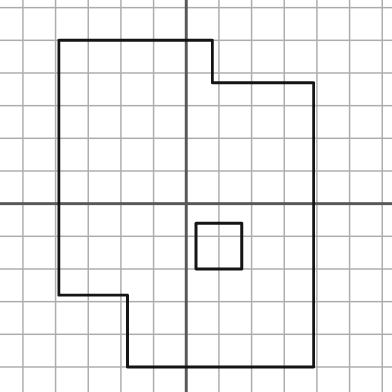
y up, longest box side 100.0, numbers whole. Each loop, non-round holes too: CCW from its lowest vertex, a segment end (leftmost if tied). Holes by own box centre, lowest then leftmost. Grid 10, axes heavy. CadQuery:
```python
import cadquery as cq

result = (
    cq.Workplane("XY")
    .moveTo(-18.0, -50.0)
    .lineTo(39.0, -50.0)
    .lineTo(39.0, 37.0)
    .lineTo(8.0, 37.0)
    .lineTo(8.0, 50.0)
    .lineTo(-39.0, 50.0)
    .lineTo(-39.0, -28.0)
    .lineTo(-18.0, -28.0)
    .close()
    .moveTo(3.0, -20.0)
    .lineTo(17.0, -20.0)
    .lineTo(17.0, -6.0)
    .lineTo(3.0, -6.0)
    .close()
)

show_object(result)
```